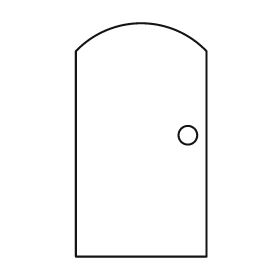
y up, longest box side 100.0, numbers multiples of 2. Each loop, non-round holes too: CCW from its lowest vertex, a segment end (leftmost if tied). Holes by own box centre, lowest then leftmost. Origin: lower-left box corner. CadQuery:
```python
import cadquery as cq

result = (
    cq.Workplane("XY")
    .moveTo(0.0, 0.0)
    .lineTo(56.0, 0.0)
    .lineTo(56.0, 88.0)
    .threePointArc((28.0, 100.0), (0.0, 88.0))
    .close()
    .moveTo(48.0, 52.0)
    .circle(4.0)
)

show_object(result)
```